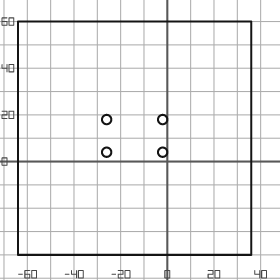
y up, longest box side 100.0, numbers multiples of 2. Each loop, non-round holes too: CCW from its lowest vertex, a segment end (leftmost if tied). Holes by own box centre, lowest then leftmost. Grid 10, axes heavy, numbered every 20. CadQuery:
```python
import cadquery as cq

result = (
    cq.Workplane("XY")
    .moveTo(-64.0, -40.0)
    .lineTo(36.0, -40.0)
    .lineTo(36.0, 60.0)
    .lineTo(-64.0, 60.0)
    .close()
    .moveTo(-26.0, 4.0)
    .circle(2.0)
    .moveTo(-2.0, 4.0)
    .circle(2.0)
    .moveTo(-26.0, 18.0)
    .circle(2.0)
    .moveTo(-2.0, 18.0)
    .circle(2.0)
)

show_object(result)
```